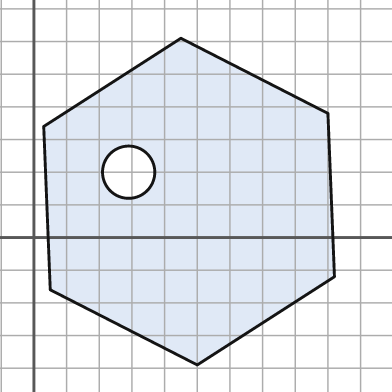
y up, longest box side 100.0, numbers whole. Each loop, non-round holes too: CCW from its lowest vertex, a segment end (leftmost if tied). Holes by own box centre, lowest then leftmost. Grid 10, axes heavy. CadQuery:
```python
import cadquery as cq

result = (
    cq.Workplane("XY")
    .moveTo(50.0, -39.0)
    .lineTo(92.0, -12.0)
    .lineTo(90.0, 38.0)
    .lineTo(45.0, 61.0)
    .lineTo(3.0, 34.0)
    .lineTo(5.0, -16.0)
    .close()
    .moveTo(29.0, 20.0)
    .circle(8.0)
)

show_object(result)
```